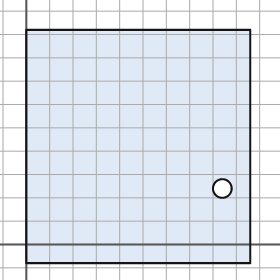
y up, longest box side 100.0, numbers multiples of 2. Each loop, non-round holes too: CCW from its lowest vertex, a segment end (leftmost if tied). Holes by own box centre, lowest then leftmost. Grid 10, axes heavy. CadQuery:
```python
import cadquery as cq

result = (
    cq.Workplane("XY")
    .moveTo(0.0, -8.0)
    .lineTo(96.0, -8.0)
    .lineTo(96.0, 92.0)
    .lineTo(0.0, 92.0)
    .close()
    .moveTo(84.0, 24.0)
    .circle(4.0)
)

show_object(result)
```